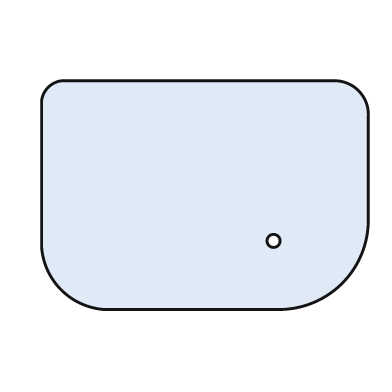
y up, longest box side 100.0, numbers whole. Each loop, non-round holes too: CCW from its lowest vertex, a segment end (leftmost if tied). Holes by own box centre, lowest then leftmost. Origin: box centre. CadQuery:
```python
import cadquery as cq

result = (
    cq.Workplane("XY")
    .moveTo(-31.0, -35.0)
    .lineTo(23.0, -35.0)
    .threePointArc((42.0, -27.0), (50.0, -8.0))
    .lineTo(50.0, 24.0)
    .threePointArc((47.0, 32.0), (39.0, 35.0))
    .lineTo(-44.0, 35.0)
    .threePointArc((-48.0, 33.0), (-50.0, 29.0))
    .lineTo(-50.0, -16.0)
    .threePointArc((-44.0, -29.0), (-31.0, -35.0))
    .close()
    .moveTo(21.0, -14.0)
    .circle(2.0)
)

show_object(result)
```